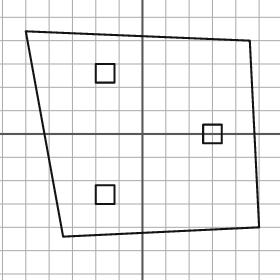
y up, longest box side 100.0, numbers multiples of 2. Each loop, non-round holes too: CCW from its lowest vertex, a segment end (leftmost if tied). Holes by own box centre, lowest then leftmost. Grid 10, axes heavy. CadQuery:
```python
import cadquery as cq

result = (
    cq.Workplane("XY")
    .moveTo(-34.0, -44.0)
    .lineTo(50.0, -40.0)
    .lineTo(46.0, 40.0)
    .lineTo(-50.0, 44.0)
    .close()
    .moveTo(-20.0, -30.0)
    .lineTo(-12.0, -30.0)
    .lineTo(-12.0, -22.0)
    .lineTo(-20.0, -22.0)
    .close()
    .moveTo(26.0, -4.0)
    .lineTo(34.0, -4.0)
    .lineTo(34.0, 4.0)
    .lineTo(26.0, 4.0)
    .close()
    .moveTo(-20.0, 22.0)
    .lineTo(-12.0, 22.0)
    .lineTo(-12.0, 30.0)
    .lineTo(-20.0, 30.0)
    .close()
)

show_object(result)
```